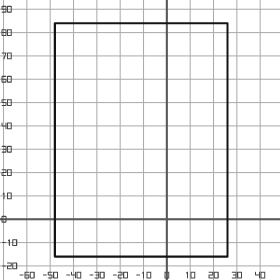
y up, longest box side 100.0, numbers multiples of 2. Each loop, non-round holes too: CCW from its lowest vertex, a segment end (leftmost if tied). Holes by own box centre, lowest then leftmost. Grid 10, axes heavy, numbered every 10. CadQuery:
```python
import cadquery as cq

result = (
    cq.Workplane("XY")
    .moveTo(-48.0, -16.0)
    .lineTo(26.0, -16.0)
    .lineTo(26.0, 84.0)
    .lineTo(-48.0, 84.0)
    .close()
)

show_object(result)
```